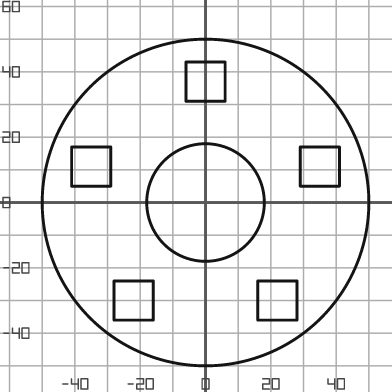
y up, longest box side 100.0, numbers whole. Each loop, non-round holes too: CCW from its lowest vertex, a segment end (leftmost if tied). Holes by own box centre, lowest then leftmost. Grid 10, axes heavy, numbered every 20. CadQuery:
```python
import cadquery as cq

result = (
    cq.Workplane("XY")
    .moveTo(0.0, 0.0)
    .circle(50.0)
    .moveTo(-28.0, -36.0)
    .lineTo(-16.0, -36.0)
    .lineTo(-16.0, -24.0)
    .lineTo(-28.0, -24.0)
    .close()
    .moveTo(16.0, -36.0)
    .lineTo(28.0, -36.0)
    .lineTo(28.0, -24.0)
    .lineTo(16.0, -24.0)
    .close()
    .moveTo(0.0, 0.0)
    .circle(18.0)
    .moveTo(-41.0, 5.0)
    .lineTo(-29.0, 5.0)
    .lineTo(-29.0, 17.0)
    .lineTo(-41.0, 17.0)
    .close()
    .moveTo(29.0, 5.0)
    .lineTo(41.0, 5.0)
    .lineTo(41.0, 17.0)
    .lineTo(29.0, 17.0)
    .close()
    .moveTo(-6.0, 31.0)
    .lineTo(6.0, 31.0)
    .lineTo(6.0, 43.0)
    .lineTo(-6.0, 43.0)
    .close()
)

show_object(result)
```